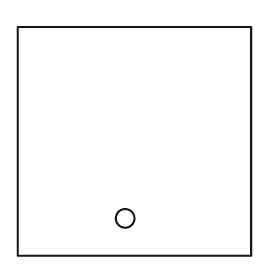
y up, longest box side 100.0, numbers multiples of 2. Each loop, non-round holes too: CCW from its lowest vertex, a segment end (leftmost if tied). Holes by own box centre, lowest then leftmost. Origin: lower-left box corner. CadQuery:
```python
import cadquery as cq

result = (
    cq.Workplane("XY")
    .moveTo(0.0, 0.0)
    .lineTo(100.0, 0.0)
    .lineTo(100.0, 98.0)
    .lineTo(0.0, 98.0)
    .close()
    .moveTo(46.0, 16.0)
    .circle(4.0)
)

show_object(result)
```